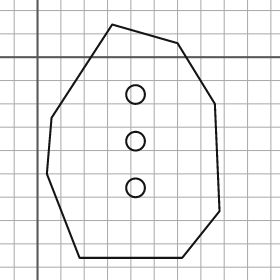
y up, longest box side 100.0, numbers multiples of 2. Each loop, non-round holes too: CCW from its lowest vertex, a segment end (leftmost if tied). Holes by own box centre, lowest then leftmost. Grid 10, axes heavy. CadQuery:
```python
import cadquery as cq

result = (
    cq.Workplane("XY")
    .moveTo(18.0, -86.0)
    .lineTo(62.0, -86.0)
    .lineTo(78.0, -66.0)
    .lineTo(76.0, -20.0)
    .lineTo(60.0, 6.0)
    .lineTo(32.0, 14.0)
    .lineTo(6.0, -26.0)
    .lineTo(4.0, -50.0)
    .close()
    .moveTo(42.0, -56.0)
    .circle(4.0)
    .moveTo(42.0, -36.0)
    .circle(4.0)
    .moveTo(42.0, -16.0)
    .circle(4.0)
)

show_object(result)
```